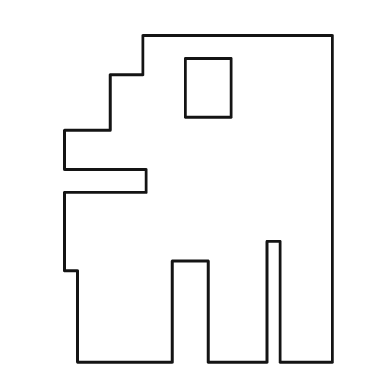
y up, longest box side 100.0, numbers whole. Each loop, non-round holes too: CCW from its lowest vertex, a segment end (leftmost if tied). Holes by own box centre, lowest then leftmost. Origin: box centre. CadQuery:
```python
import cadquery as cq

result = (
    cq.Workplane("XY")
    .moveTo(-37.0, -50.0)
    .lineTo(-8.0, -50.0)
    .lineTo(-8.0, -19.0)
    .lineTo(3.0, -19.0)
    .lineTo(3.0, -50.0)
    .lineTo(21.0, -50.0)
    .lineTo(21.0, -13.0)
    .lineTo(25.0, -13.0)
    .lineTo(25.0, -50.0)
    .lineTo(41.0, -50.0)
    .lineTo(41.0, 50.0)
    .lineTo(-17.0, 50.0)
    .lineTo(-17.0, 38.0)
    .lineTo(-27.0, 38.0)
    .lineTo(-27.0, 21.0)
    .lineTo(-41.0, 21.0)
    .lineTo(-41.0, 9.0)
    .lineTo(-16.0, 9.0)
    .lineTo(-16.0, 2.0)
    .lineTo(-41.0, 2.0)
    .lineTo(-41.0, -22.0)
    .lineTo(-37.0, -22.0)
    .close()
    .moveTo(-4.0, 25.0)
    .lineTo(10.0, 25.0)
    .lineTo(10.0, 43.0)
    .lineTo(-4.0, 43.0)
    .close()
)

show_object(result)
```